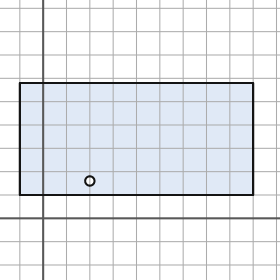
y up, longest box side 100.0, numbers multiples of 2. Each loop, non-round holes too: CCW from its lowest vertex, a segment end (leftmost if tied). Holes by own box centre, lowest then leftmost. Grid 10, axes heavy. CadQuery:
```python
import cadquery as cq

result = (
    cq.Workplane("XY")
    .moveTo(-10.0, 10.0)
    .lineTo(90.0, 10.0)
    .lineTo(90.0, 58.0)
    .lineTo(-10.0, 58.0)
    .close()
    .moveTo(20.0, 16.0)
    .circle(2.0)
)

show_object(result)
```